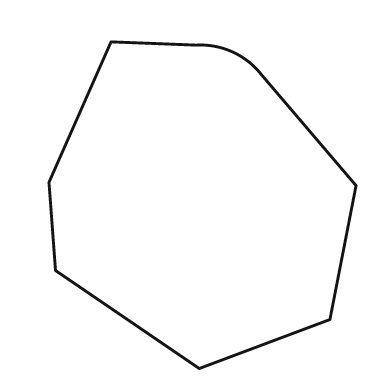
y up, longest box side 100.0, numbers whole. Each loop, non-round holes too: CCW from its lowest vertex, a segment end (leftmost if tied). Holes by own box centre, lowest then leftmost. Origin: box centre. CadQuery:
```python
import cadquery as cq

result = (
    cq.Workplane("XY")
    .moveTo(-1.0, -50.0)
    .lineTo(39.0, -35.0)
    .lineTo(47.0, 6.0)
    .lineTo(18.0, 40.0)
    .threePointArc((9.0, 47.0), (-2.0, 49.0))
    .lineTo(-28.0, 50.0)
    .lineTo(-47.0, 7.0)
    .lineTo(-45.0, -20.0)
    .close()
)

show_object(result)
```